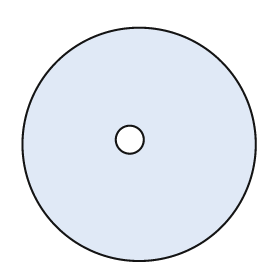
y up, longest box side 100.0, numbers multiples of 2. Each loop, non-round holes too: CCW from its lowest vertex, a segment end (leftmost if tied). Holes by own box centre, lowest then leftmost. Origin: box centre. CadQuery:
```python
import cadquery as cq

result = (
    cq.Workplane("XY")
    .moveTo(0.0, 0.0)
    .circle(50.0)
    .moveTo(-4.0, 2.0)
    .circle(6.0)
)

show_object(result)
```